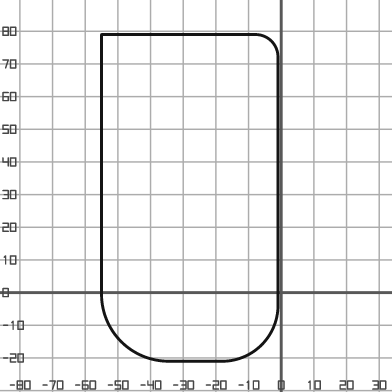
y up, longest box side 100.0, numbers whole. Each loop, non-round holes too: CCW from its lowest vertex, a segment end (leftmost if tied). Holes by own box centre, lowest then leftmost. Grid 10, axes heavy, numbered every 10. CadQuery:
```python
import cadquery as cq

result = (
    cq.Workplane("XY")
    .moveTo(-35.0, -21.0)
    .lineTo(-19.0, -21.0)
    .threePointArc((-6.0, -16.0), (-1.0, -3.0))
    .lineTo(-1.0, 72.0)
    .threePointArc((-3.0, 77.0), (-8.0, 79.0))
    .lineTo(-55.0, 79.0)
    .lineTo(-55.0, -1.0)
    .threePointArc((-49.0, -15.0), (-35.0, -21.0))
    .close()
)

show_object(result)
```